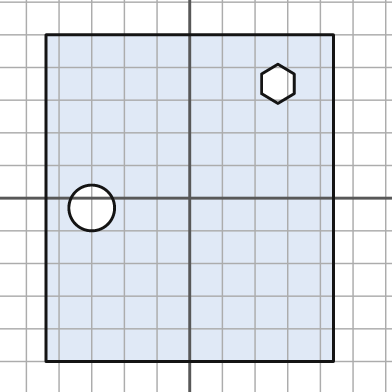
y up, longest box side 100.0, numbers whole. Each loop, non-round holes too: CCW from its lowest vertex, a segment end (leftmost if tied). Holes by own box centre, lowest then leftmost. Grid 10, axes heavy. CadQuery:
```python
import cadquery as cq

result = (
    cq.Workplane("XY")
    .moveTo(-44.0, -50.0)
    .lineTo(44.0, -50.0)
    .lineTo(44.0, 50.0)
    .lineTo(-44.0, 50.0)
    .close()
    .moveTo(-30.0, -3.0)
    .circle(7.0)
    .moveTo(27.0, 29.0)
    .lineTo(32.0, 32.0)
    .lineTo(32.0, 38.0)
    .lineTo(27.0, 41.0)
    .lineTo(22.0, 38.0)
    .lineTo(22.0, 32.0)
    .close()
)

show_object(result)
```